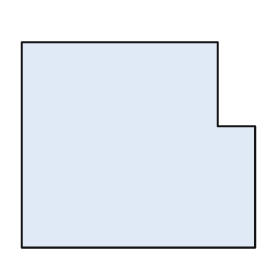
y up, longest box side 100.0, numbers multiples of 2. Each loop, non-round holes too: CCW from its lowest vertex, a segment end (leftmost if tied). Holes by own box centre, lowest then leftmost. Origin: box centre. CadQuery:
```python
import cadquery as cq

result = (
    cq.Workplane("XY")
    .moveTo(-50.0, -44.0)
    .lineTo(50.0, -44.0)
    .lineTo(50.0, 8.0)
    .lineTo(34.0, 8.0)
    .lineTo(34.0, 44.0)
    .lineTo(-50.0, 44.0)
    .close()
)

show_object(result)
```